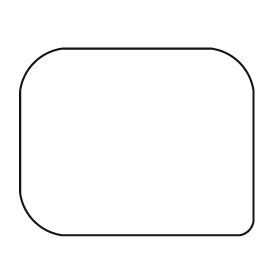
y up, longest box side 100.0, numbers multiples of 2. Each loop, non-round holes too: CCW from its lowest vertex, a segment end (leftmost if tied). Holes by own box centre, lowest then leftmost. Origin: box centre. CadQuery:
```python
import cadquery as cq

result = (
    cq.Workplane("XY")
    .moveTo(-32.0, -40.0)
    .lineTo(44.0, -40.0)
    .threePointArc((48.0, -38.0), (50.0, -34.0))
    .lineTo(50.0, 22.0)
    .threePointArc((44.0, 34.0), (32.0, 40.0))
    .lineTo(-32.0, 40.0)
    .threePointArc((-44.0, 34.0), (-50.0, 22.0))
    .lineTo(-50.0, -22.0)
    .threePointArc((-44.0, -34.0), (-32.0, -40.0))
    .close()
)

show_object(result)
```